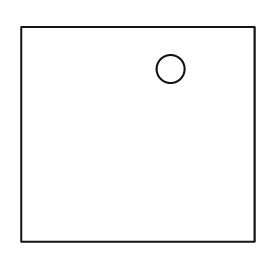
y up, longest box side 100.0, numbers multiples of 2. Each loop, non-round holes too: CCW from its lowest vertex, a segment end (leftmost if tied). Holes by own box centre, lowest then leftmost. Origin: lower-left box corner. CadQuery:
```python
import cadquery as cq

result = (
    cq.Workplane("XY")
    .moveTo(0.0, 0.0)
    .lineTo(100.0, 0.0)
    .lineTo(100.0, 92.0)
    .lineTo(0.0, 92.0)
    .close()
    .moveTo(64.0, 74.0)
    .circle(6.0)
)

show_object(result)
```